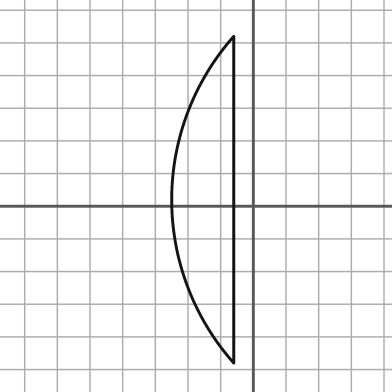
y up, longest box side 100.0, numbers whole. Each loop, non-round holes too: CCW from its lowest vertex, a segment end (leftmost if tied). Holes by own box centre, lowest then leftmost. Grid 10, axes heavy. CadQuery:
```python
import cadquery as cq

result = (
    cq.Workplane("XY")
    .moveTo(-6.0, -48.0)
    .lineTo(-6.0, 52.0)
    .threePointArc((-25.0, 2.0), (-6.0, -48.0))
    .close()
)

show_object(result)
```